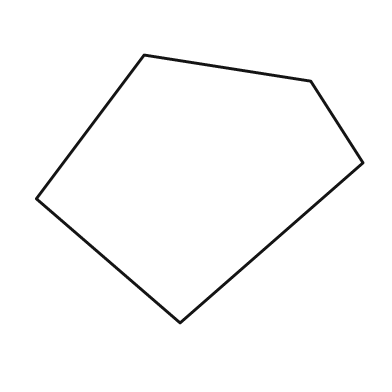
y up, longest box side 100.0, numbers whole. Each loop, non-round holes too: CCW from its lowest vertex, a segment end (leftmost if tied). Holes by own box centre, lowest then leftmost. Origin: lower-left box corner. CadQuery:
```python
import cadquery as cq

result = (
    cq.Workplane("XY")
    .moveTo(44.0, 0.0)
    .lineTo(100.0, 49.0)
    .lineTo(84.0, 74.0)
    .lineTo(33.0, 82.0)
    .lineTo(0.0, 38.0)
    .close()
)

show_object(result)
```